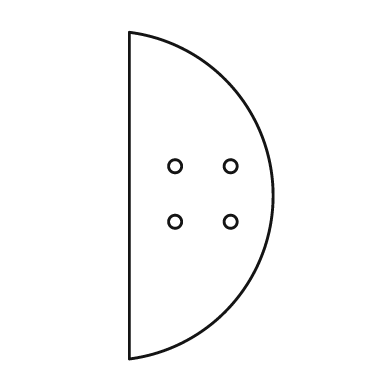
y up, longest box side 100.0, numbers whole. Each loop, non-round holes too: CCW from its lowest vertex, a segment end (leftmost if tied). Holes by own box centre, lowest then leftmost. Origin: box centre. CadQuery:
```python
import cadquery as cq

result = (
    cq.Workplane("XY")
    .moveTo(-22.0, -50.0)
    .threePointArc((22.0, 0.0), (-22.0, 50.0))
    .close()
    .moveTo(-8.0, -8.0)
    .circle(2.0)
    .moveTo(9.0, -8.0)
    .circle(2.0)
    .moveTo(-8.0, 9.0)
    .circle(2.0)
    .moveTo(9.0, 9.0)
    .circle(2.0)
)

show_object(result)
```